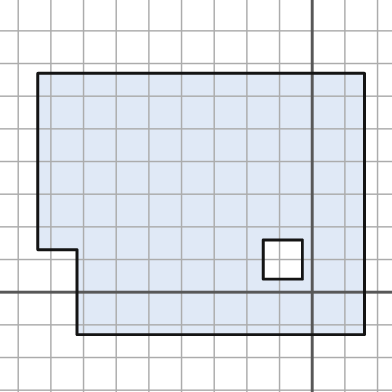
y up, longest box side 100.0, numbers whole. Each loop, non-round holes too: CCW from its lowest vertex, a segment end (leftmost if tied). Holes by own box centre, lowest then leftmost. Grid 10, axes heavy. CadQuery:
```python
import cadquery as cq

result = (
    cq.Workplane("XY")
    .moveTo(-72.0, -13.0)
    .lineTo(16.0, -13.0)
    .lineTo(16.0, 67.0)
    .lineTo(-84.0, 67.0)
    .lineTo(-84.0, 13.0)
    .lineTo(-72.0, 13.0)
    .close()
    .moveTo(-15.0, 4.0)
    .lineTo(-3.0, 4.0)
    .lineTo(-3.0, 16.0)
    .lineTo(-15.0, 16.0)
    .close()
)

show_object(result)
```